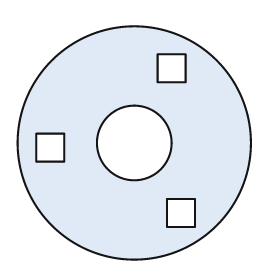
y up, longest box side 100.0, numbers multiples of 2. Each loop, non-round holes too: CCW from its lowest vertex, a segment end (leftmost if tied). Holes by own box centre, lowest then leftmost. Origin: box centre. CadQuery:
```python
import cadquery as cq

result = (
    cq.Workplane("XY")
    .moveTo(0.0, 0.0)
    .circle(50.0)
    .moveTo(14.0, -36.0)
    .lineTo(26.0, -36.0)
    .lineTo(26.0, -24.0)
    .lineTo(14.0, -24.0)
    .close()
    .moveTo(-42.0, -8.0)
    .lineTo(-30.0, -8.0)
    .lineTo(-30.0, 4.0)
    .lineTo(-42.0, 4.0)
    .close()
    .moveTo(0.0, 0.0)
    .circle(16.0)
    .moveTo(10.0, 26.0)
    .lineTo(22.0, 26.0)
    .lineTo(22.0, 38.0)
    .lineTo(10.0, 38.0)
    .close()
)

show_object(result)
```